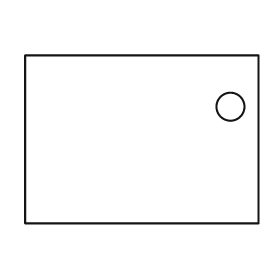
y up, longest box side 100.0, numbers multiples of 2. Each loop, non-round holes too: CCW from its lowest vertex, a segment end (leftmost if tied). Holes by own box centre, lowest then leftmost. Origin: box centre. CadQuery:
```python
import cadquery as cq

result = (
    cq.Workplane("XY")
    .moveTo(-50.0, -36.0)
    .lineTo(50.0, -36.0)
    .lineTo(50.0, 36.0)
    .lineTo(-50.0, 36.0)
    .close()
    .moveTo(38.0, 14.0)
    .circle(6.0)
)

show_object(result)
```